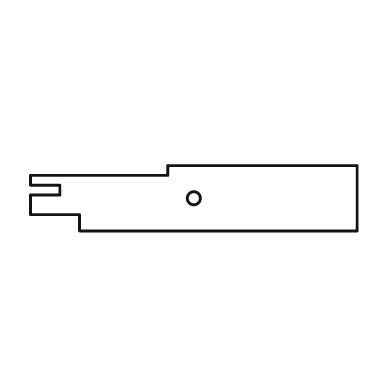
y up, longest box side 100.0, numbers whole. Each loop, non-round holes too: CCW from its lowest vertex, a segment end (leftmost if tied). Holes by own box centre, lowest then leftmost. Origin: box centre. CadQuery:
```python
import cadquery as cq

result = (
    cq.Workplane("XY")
    .moveTo(-35.0, -10.0)
    .lineTo(50.0, -10.0)
    .lineTo(50.0, 10.0)
    .lineTo(-8.0, 10.0)
    .lineTo(-8.0, 7.0)
    .lineTo(-50.0, 7.0)
    .lineTo(-50.0, 4.0)
    .lineTo(-41.0, 4.0)
    .lineTo(-41.0, 1.0)
    .lineTo(-50.0, 1.0)
    .lineTo(-50.0, -5.0)
    .lineTo(-35.0, -5.0)
    .close()
    .moveTo(0.0, 0.0)
    .circle(2.0)
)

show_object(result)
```